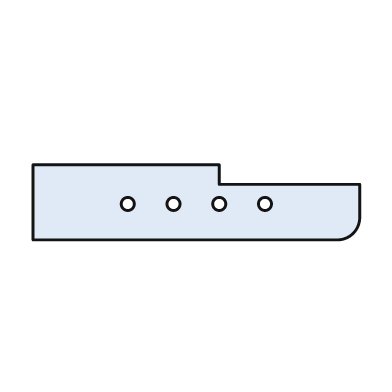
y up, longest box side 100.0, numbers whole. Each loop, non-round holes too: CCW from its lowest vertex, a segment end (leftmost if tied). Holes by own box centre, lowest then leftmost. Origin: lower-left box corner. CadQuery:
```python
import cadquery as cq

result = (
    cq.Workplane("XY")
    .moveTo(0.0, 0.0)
    .lineTo(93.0, 0.0)
    .threePointArc((98.0, 2.0), (100.0, 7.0))
    .lineTo(100.0, 17.0)
    .lineTo(57.0, 17.0)
    .lineTo(57.0, 23.0)
    .lineTo(0.0, 23.0)
    .close()
    .moveTo(29.0, 11.0)
    .circle(2.0)
    .moveTo(43.0, 11.0)
    .circle(2.0)
    .moveTo(57.0, 11.0)
    .circle(2.0)
    .moveTo(71.0, 11.0)
    .circle(2.0)
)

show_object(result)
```